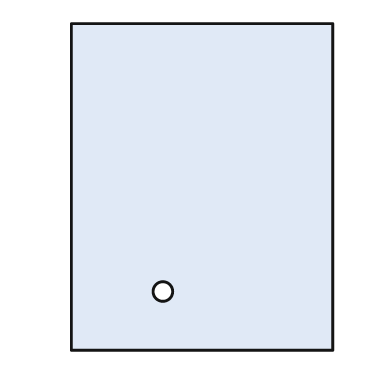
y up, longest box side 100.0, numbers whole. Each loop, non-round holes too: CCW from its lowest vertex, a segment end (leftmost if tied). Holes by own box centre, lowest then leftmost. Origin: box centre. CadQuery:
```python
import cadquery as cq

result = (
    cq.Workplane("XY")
    .moveTo(-40.0, -50.0)
    .lineTo(40.0, -50.0)
    .lineTo(40.0, 50.0)
    .lineTo(-40.0, 50.0)
    .close()
    .moveTo(-12.0, -32.0)
    .circle(3.0)
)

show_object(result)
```